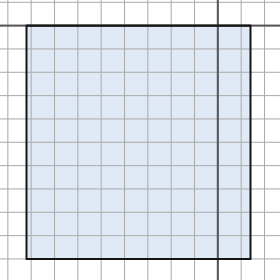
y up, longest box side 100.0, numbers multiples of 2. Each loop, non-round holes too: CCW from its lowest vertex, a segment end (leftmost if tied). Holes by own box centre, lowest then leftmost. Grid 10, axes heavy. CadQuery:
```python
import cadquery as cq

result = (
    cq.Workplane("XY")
    .moveTo(-82.0, -100.0)
    .lineTo(14.0, -100.0)
    .lineTo(14.0, 0.0)
    .lineTo(-82.0, 0.0)
    .close()
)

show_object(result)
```